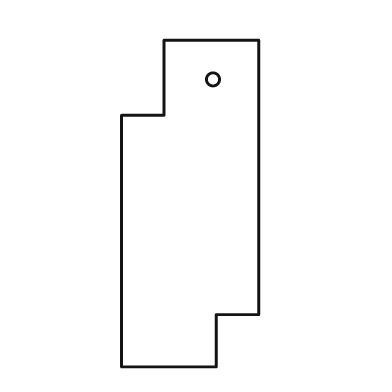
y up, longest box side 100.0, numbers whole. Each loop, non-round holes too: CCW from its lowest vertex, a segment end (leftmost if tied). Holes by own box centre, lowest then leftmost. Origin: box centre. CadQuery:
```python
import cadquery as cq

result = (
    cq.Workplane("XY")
    .moveTo(-21.0, -50.0)
    .lineTo(8.0, -50.0)
    .lineTo(8.0, -34.0)
    .lineTo(21.0, -34.0)
    .lineTo(21.0, 50.0)
    .lineTo(-8.0, 50.0)
    .lineTo(-8.0, 27.0)
    .lineTo(-21.0, 27.0)
    .close()
    .moveTo(7.0, 38.0)
    .circle(2.0)
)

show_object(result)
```